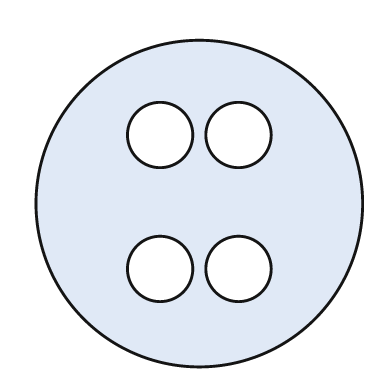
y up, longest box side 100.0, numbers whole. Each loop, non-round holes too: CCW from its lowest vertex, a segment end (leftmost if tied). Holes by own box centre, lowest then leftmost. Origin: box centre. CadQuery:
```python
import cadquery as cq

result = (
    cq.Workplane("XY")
    .moveTo(0.0, 0.0)
    .circle(50.0)
    .moveTo(-12.0, -20.0)
    .circle(10.0)
    .moveTo(12.0, -20.0)
    .circle(10.0)
    .moveTo(-12.0, 21.0)
    .circle(10.0)
    .moveTo(12.0, 21.0)
    .circle(10.0)
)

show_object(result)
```